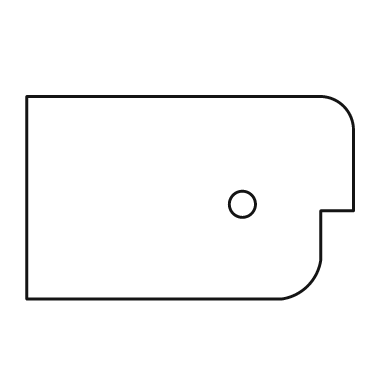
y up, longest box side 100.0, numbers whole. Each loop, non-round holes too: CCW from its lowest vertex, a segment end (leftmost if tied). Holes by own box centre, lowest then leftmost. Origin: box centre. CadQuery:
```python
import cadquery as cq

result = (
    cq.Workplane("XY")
    .moveTo(-50.0, -31.0)
    .lineTo(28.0, -31.0)
    .threePointArc((36.0, -27.0), (40.0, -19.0))
    .lineTo(40.0, -4.0)
    .lineTo(50.0, -4.0)
    .lineTo(50.0, 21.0)
    .threePointArc((47.0, 28.0), (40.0, 31.0))
    .lineTo(-50.0, 31.0)
    .close()
    .moveTo(16.0, -2.0)
    .circle(4.0)
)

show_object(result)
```